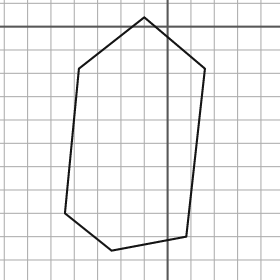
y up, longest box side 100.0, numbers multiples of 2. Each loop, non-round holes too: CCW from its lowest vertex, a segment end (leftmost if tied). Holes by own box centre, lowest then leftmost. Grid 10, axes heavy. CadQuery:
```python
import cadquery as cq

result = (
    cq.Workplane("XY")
    .moveTo(-24.0, -96.0)
    .lineTo(8.0, -90.0)
    .lineTo(16.0, -18.0)
    .lineTo(-10.0, 4.0)
    .lineTo(-38.0, -18.0)
    .lineTo(-44.0, -80.0)
    .close()
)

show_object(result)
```